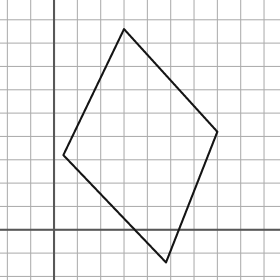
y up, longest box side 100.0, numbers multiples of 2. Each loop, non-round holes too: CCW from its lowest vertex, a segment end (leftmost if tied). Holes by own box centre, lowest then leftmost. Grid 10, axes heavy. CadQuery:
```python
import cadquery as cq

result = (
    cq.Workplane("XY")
    .moveTo(48.0, -14.0)
    .lineTo(70.0, 42.0)
    .lineTo(30.0, 86.0)
    .lineTo(4.0, 32.0)
    .close()
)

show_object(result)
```